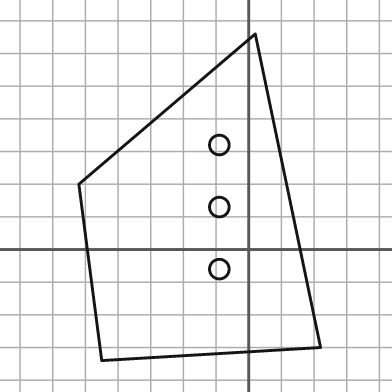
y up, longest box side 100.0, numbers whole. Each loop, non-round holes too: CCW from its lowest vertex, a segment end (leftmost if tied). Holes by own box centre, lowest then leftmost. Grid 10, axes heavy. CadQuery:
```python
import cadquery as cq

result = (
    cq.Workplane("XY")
    .moveTo(-45.0, -34.0)
    .lineTo(22.0, -30.0)
    .lineTo(2.0, 66.0)
    .lineTo(-52.0, 20.0)
    .close()
    .moveTo(-9.0, -6.0)
    .circle(3.0)
    .moveTo(-9.0, 13.0)
    .circle(3.0)
    .moveTo(-9.0, 32.0)
    .circle(3.0)
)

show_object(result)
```